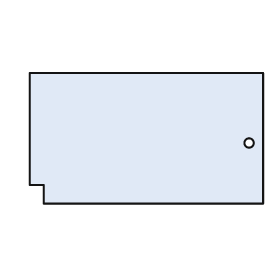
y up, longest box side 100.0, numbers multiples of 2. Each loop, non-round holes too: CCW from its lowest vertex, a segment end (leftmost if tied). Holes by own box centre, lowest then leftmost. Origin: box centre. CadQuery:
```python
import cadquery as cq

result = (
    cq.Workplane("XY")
    .moveTo(-44.0, -28.0)
    .lineTo(50.0, -28.0)
    .lineTo(50.0, 28.0)
    .lineTo(-50.0, 28.0)
    .lineTo(-50.0, -20.0)
    .lineTo(-44.0, -20.0)
    .close()
    .moveTo(44.0, -2.0)
    .circle(2.0)
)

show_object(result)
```